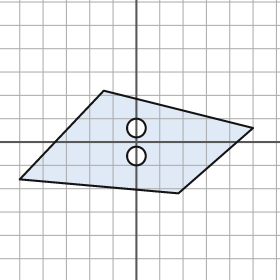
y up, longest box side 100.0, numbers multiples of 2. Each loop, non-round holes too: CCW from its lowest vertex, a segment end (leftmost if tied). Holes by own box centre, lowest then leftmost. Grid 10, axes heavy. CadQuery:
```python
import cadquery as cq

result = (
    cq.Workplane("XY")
    .moveTo(18.0, -22.0)
    .lineTo(50.0, 6.0)
    .lineTo(-14.0, 22.0)
    .lineTo(-50.0, -16.0)
    .close()
    .moveTo(0.0, -6.0)
    .circle(4.0)
    .moveTo(0.0, 6.0)
    .circle(4.0)
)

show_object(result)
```